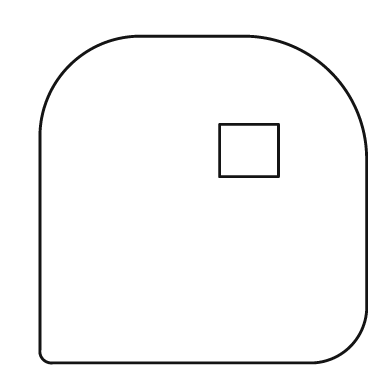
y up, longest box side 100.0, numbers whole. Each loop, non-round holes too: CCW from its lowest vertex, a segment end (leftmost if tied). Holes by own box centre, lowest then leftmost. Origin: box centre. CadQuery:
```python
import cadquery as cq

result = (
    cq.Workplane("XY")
    .moveTo(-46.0, -50.0)
    .lineTo(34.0, -50.0)
    .threePointArc((45.0, -45.0), (50.0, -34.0))
    .lineTo(50.0, 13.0)
    .threePointArc((39.0, 39.0), (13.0, 50.0))
    .lineTo(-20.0, 50.0)
    .threePointArc((-41.0, 41.0), (-50.0, 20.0))
    .lineTo(-50.0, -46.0)
    .threePointArc((-49.0, -49.0), (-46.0, -50.0))
    .close()
    .moveTo(5.0, 7.0)
    .lineTo(23.0, 7.0)
    .lineTo(23.0, 23.0)
    .lineTo(5.0, 23.0)
    .close()
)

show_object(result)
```